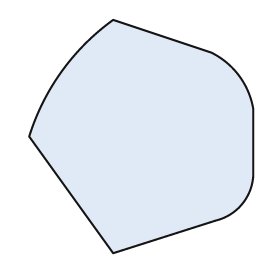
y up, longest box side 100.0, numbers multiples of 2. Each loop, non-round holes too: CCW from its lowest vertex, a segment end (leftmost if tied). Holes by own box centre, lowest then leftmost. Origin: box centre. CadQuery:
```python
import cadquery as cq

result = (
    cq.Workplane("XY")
    .moveTo(-12.0, -50.0)
    .lineTo(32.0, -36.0)
    .threePointArc((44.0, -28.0), (48.0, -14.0))
    .lineTo(48.0, 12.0)
    .threePointArc((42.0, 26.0), (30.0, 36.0))
    .lineTo(-12.0, 50.0)
    .threePointArc((-34.0, 28.0), (-48.0, 0.0))
    .close()
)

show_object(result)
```